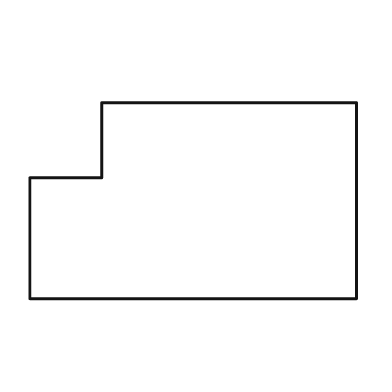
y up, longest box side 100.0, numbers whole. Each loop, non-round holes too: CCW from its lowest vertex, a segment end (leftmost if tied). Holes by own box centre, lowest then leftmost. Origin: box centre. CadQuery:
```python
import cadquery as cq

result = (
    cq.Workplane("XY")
    .moveTo(-50.0, -30.0)
    .lineTo(50.0, -30.0)
    .lineTo(50.0, 30.0)
    .lineTo(-28.0, 30.0)
    .lineTo(-28.0, 7.0)
    .lineTo(-50.0, 7.0)
    .close()
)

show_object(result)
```